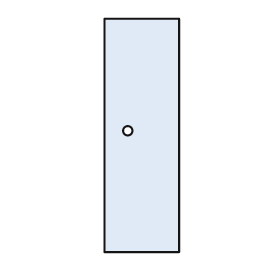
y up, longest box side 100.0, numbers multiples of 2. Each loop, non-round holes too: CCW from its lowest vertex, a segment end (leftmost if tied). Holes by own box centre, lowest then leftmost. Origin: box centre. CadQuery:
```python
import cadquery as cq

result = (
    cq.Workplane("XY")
    .moveTo(-16.0, -50.0)
    .lineTo(16.0, -50.0)
    .lineTo(16.0, 50.0)
    .lineTo(-16.0, 50.0)
    .close()
    .moveTo(-6.0, 2.0)
    .circle(2.0)
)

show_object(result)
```